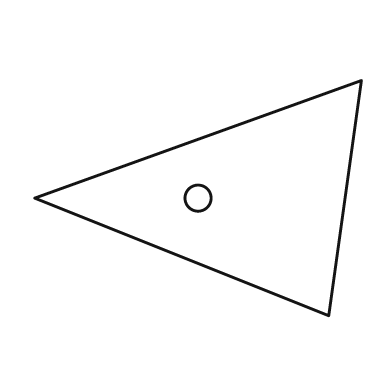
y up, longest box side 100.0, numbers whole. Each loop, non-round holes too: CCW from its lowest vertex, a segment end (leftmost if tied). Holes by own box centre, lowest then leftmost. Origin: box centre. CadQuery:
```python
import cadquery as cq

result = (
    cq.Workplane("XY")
    .moveTo(40.0, -36.0)
    .lineTo(50.0, 36.0)
    .lineTo(-50.0, 0.0)
    .close()
    .moveTo(0.0, 0.0)
    .circle(4.0)
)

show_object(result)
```